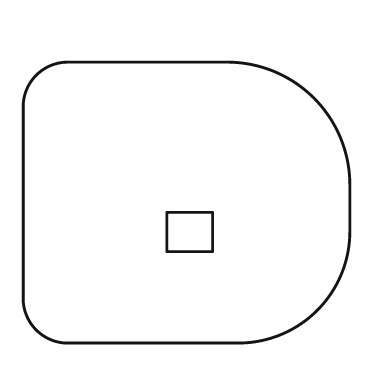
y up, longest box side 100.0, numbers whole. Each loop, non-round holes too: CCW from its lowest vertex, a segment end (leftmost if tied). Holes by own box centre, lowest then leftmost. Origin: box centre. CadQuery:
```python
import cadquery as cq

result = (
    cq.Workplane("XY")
    .moveTo(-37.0, -43.0)
    .lineTo(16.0, -43.0)
    .threePointArc((40.0, -33.0), (50.0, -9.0))
    .lineTo(50.0, 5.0)
    .threePointArc((39.0, 32.0), (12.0, 43.0))
    .lineTo(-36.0, 43.0)
    .threePointArc((-46.0, 39.0), (-50.0, 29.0))
    .lineTo(-50.0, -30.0)
    .threePointArc((-46.0, -39.0), (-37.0, -43.0))
    .close()
    .moveTo(-6.0, -15.0)
    .lineTo(8.0, -15.0)
    .lineTo(8.0, -3.0)
    .lineTo(-6.0, -3.0)
    .close()
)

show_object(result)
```